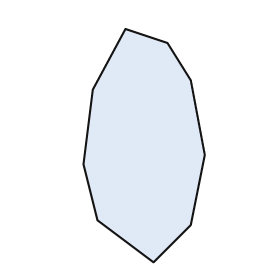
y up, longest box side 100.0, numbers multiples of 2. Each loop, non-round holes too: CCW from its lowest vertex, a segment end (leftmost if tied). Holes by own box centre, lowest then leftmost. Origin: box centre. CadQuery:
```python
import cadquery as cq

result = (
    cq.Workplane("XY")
    .moveTo(4.0, -50.0)
    .lineTo(20.0, -34.0)
    .lineTo(26.0, -4.0)
    .lineTo(20.0, 28.0)
    .lineTo(10.0, 44.0)
    .lineTo(-8.0, 50.0)
    .lineTo(-22.0, 24.0)
    .lineTo(-26.0, -8.0)
    .lineTo(-20.0, -32.0)
    .close()
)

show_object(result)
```